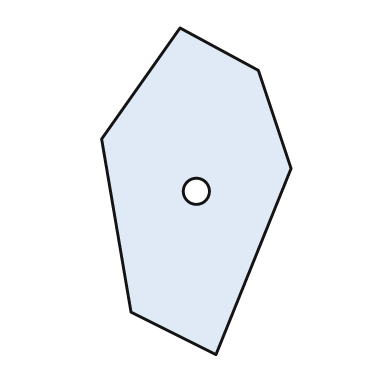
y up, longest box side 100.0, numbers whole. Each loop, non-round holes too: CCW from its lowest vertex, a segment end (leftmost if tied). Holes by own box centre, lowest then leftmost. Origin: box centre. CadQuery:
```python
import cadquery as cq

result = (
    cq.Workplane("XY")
    .moveTo(6.0, -50.0)
    .lineTo(29.0, 7.0)
    .lineTo(19.0, 37.0)
    .lineTo(-5.0, 50.0)
    .lineTo(-29.0, 16.0)
    .lineTo(-20.0, -37.0)
    .close()
    .moveTo(0.0, 0.0)
    .circle(4.0)
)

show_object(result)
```